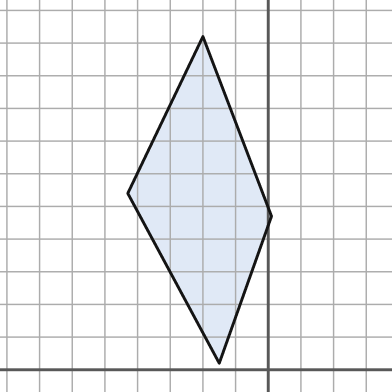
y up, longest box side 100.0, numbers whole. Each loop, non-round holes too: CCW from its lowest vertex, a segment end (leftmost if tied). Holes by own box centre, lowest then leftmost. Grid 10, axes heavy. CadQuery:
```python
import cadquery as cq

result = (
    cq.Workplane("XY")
    .moveTo(-15.0, 2.0)
    .lineTo(1.0, 47.0)
    .lineTo(-20.0, 102.0)
    .lineTo(-43.0, 54.0)
    .close()
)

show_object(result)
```